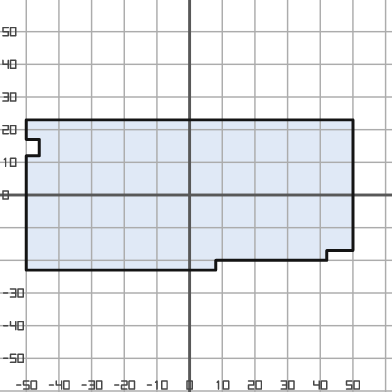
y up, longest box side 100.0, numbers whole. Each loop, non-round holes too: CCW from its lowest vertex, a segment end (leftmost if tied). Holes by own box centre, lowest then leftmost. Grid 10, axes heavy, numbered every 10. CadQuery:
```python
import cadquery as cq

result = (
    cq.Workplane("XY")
    .moveTo(-50.0, -23.0)
    .lineTo(8.0, -23.0)
    .lineTo(8.0, -20.0)
    .lineTo(42.0, -20.0)
    .lineTo(42.0, -17.0)
    .lineTo(50.0, -17.0)
    .lineTo(50.0, 23.0)
    .lineTo(-50.0, 23.0)
    .lineTo(-50.0, 17.0)
    .lineTo(-46.0, 17.0)
    .lineTo(-46.0, 12.0)
    .lineTo(-50.0, 12.0)
    .close()
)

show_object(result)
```